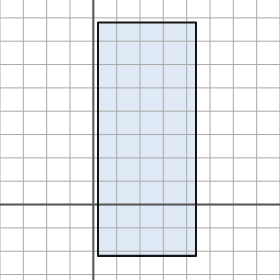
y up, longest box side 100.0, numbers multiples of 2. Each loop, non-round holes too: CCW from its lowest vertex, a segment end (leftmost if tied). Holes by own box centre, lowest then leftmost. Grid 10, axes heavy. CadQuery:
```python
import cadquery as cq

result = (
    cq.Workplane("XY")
    .moveTo(2.0, -22.0)
    .lineTo(44.0, -22.0)
    .lineTo(44.0, 78.0)
    .lineTo(2.0, 78.0)
    .close()
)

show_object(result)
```